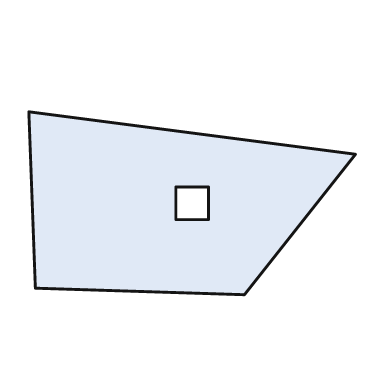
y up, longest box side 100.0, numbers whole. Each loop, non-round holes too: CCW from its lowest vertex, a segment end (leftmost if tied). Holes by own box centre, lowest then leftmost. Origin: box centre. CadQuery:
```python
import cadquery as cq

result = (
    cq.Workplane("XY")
    .moveTo(16.0, -28.0)
    .lineTo(50.0, 15.0)
    .lineTo(-50.0, 28.0)
    .lineTo(-48.0, -26.0)
    .close()
    .moveTo(-5.0, -5.0)
    .lineTo(5.0, -5.0)
    .lineTo(5.0, 5.0)
    .lineTo(-5.0, 5.0)
    .close()
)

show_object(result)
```